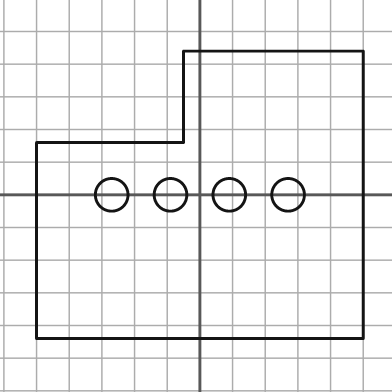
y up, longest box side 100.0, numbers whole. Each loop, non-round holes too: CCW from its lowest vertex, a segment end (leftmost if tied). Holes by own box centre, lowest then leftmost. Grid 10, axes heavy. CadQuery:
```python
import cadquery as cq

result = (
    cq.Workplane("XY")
    .moveTo(-50.0, -44.0)
    .lineTo(50.0, -44.0)
    .lineTo(50.0, 44.0)
    .lineTo(-5.0, 44.0)
    .lineTo(-5.0, 16.0)
    .lineTo(-50.0, 16.0)
    .close()
    .moveTo(-27.0, 0.0)
    .circle(5.0)
    .moveTo(-9.0, 0.0)
    .circle(5.0)
    .moveTo(9.0, 0.0)
    .circle(5.0)
    .moveTo(27.0, 0.0)
    .circle(5.0)
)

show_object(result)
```